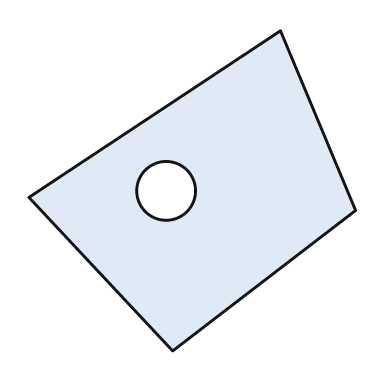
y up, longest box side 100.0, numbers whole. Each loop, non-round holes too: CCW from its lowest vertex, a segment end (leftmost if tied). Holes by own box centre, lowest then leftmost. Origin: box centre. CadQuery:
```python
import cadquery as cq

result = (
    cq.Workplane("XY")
    .moveTo(-6.0, -49.0)
    .lineTo(50.0, -6.0)
    .lineTo(27.0, 49.0)
    .lineTo(-50.0, -2.0)
    .close()
    .moveTo(-8.0, 0.0)
    .circle(9.0)
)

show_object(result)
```